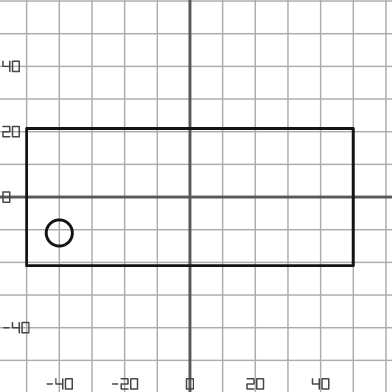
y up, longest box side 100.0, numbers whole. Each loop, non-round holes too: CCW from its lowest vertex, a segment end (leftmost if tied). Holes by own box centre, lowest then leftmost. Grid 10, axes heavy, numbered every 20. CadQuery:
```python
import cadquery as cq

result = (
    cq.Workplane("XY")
    .moveTo(-50.0, -21.0)
    .lineTo(50.0, -21.0)
    .lineTo(50.0, 21.0)
    .lineTo(-50.0, 21.0)
    .close()
    .moveTo(-40.0, -11.0)
    .circle(4.0)
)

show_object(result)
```